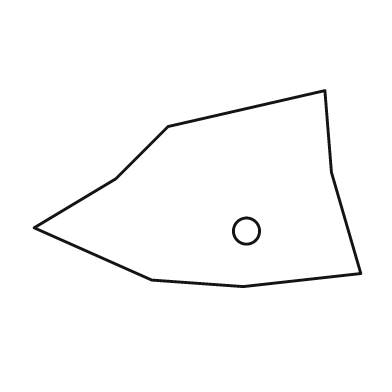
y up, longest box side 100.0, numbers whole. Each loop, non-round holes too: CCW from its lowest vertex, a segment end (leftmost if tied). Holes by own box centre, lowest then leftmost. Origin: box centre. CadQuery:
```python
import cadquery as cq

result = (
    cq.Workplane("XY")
    .moveTo(14.0, -30.0)
    .lineTo(50.0, -26.0)
    .lineTo(41.0, 5.0)
    .lineTo(39.0, 30.0)
    .lineTo(-9.0, 19.0)
    .lineTo(-25.0, 3.0)
    .lineTo(-50.0, -12.0)
    .lineTo(-14.0, -28.0)
    .close()
    .moveTo(15.0, -13.0)
    .circle(4.0)
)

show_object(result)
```